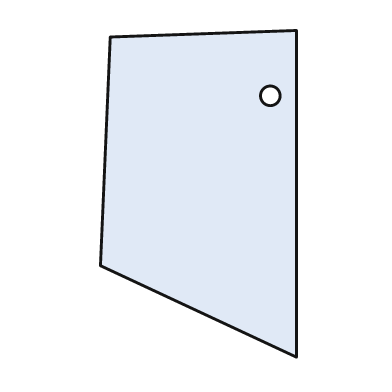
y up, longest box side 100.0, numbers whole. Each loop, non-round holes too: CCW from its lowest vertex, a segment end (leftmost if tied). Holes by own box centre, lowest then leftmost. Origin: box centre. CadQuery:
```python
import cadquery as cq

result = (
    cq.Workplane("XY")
    .moveTo(30.0, -50.0)
    .lineTo(30.0, 50.0)
    .lineTo(-27.0, 48.0)
    .lineTo(-30.0, -22.0)
    .close()
    .moveTo(22.0, 30.0)
    .circle(3.0)
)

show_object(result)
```